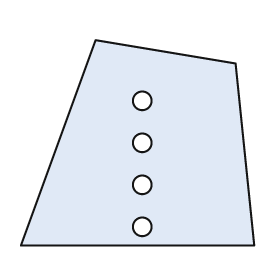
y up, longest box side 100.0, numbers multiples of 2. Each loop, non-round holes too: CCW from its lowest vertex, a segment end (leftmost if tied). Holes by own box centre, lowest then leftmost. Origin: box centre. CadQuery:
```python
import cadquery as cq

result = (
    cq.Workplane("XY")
    .moveTo(-50.0, -44.0)
    .lineTo(50.0, -44.0)
    .lineTo(42.0, 34.0)
    .lineTo(-18.0, 44.0)
    .close()
    .moveTo(2.0, -36.0)
    .circle(4.0)
    .moveTo(2.0, -18.0)
    .circle(4.0)
    .moveTo(2.0, 0.0)
    .circle(4.0)
    .moveTo(2.0, 18.0)
    .circle(4.0)
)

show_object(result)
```